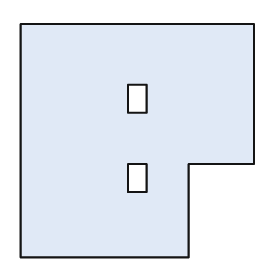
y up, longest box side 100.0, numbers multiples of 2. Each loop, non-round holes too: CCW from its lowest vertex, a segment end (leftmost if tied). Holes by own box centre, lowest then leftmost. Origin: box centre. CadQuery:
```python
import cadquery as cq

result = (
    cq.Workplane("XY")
    .moveTo(-50.0, -50.0)
    .lineTo(22.0, -50.0)
    .lineTo(22.0, -10.0)
    .lineTo(50.0, -10.0)
    .lineTo(50.0, 50.0)
    .lineTo(-50.0, 50.0)
    .close()
    .moveTo(-4.0, -22.0)
    .lineTo(4.0, -22.0)
    .lineTo(4.0, -10.0)
    .lineTo(-4.0, -10.0)
    .close()
    .moveTo(-4.0, 12.0)
    .lineTo(4.0, 12.0)
    .lineTo(4.0, 24.0)
    .lineTo(-4.0, 24.0)
    .close()
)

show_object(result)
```